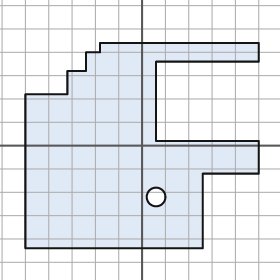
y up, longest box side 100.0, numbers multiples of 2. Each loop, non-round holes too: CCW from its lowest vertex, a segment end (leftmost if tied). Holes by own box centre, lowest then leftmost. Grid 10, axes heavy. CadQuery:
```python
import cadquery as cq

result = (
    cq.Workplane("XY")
    .moveTo(-50.0, -44.0)
    .lineTo(26.0, -44.0)
    .lineTo(26.0, -12.0)
    .lineTo(50.0, -12.0)
    .lineTo(50.0, 2.0)
    .lineTo(6.0, 2.0)
    .lineTo(6.0, 36.0)
    .lineTo(50.0, 36.0)
    .lineTo(50.0, 44.0)
    .lineTo(-18.0, 44.0)
    .lineTo(-18.0, 40.0)
    .lineTo(-24.0, 40.0)
    .lineTo(-24.0, 32.0)
    .lineTo(-32.0, 32.0)
    .lineTo(-32.0, 22.0)
    .lineTo(-50.0, 22.0)
    .close()
    .moveTo(6.0, -22.0)
    .circle(4.0)
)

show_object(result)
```